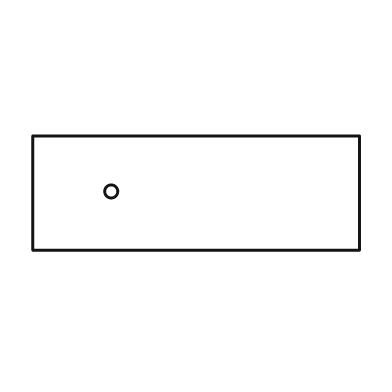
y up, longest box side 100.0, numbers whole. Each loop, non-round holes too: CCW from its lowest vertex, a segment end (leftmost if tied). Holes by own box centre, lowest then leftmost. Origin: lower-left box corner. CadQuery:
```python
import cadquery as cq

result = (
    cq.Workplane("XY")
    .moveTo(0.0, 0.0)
    .lineTo(100.0, 0.0)
    .lineTo(100.0, 35.0)
    .lineTo(0.0, 35.0)
    .close()
    .moveTo(24.0, 18.0)
    .circle(2.0)
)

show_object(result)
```